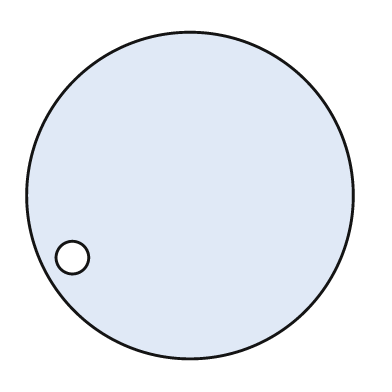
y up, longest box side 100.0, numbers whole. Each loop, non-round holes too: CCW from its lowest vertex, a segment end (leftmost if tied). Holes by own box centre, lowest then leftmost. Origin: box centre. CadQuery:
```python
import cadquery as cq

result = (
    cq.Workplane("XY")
    .moveTo(0.0, 0.0)
    .circle(50.0)
    .moveTo(-36.0, -19.0)
    .circle(5.0)
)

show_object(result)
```